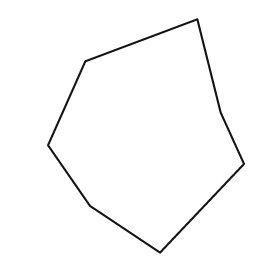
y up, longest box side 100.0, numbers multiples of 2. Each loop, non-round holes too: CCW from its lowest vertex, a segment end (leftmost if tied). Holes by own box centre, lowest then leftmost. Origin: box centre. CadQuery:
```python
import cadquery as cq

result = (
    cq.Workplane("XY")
    .moveTo(6.0, -50.0)
    .lineTo(42.0, -12.0)
    .lineTo(32.0, 10.0)
    .lineTo(22.0, 50.0)
    .lineTo(-26.0, 32.0)
    .lineTo(-42.0, -4.0)
    .lineTo(-24.0, -30.0)
    .close()
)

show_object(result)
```